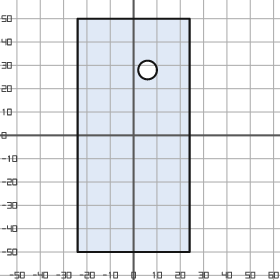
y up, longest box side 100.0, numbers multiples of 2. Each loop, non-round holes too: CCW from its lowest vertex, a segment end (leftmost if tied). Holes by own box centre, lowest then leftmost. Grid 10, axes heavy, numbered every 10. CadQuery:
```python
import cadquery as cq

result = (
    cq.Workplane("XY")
    .moveTo(-24.0, -50.0)
    .lineTo(24.0, -50.0)
    .lineTo(24.0, 50.0)
    .lineTo(-24.0, 50.0)
    .close()
    .moveTo(6.0, 28.0)
    .circle(4.0)
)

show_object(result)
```